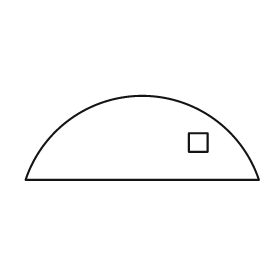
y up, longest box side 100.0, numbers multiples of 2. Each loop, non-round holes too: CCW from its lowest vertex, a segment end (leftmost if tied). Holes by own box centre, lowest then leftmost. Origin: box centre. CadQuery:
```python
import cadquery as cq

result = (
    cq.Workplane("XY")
    .moveTo(-50.0, -18.0)
    .lineTo(50.0, -18.0)
    .threePointArc((0.0, 18.0), (-50.0, -18.0))
    .close()
    .moveTo(20.0, -6.0)
    .lineTo(28.0, -6.0)
    .lineTo(28.0, 2.0)
    .lineTo(20.0, 2.0)
    .close()
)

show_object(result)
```